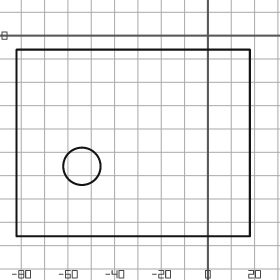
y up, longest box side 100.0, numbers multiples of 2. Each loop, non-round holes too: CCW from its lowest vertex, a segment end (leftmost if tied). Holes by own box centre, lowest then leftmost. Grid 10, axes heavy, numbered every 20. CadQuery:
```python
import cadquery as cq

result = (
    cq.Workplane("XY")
    .moveTo(-82.0, -86.0)
    .lineTo(18.0, -86.0)
    .lineTo(18.0, -6.0)
    .lineTo(-82.0, -6.0)
    .close()
    .moveTo(-54.0, -56.0)
    .circle(8.0)
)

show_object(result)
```